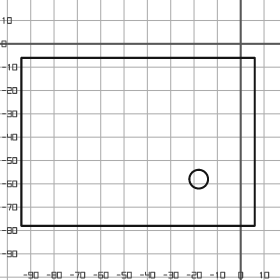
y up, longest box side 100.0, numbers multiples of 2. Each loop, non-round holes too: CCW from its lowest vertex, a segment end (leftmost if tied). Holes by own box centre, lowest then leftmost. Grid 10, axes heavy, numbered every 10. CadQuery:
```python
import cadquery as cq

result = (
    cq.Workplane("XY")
    .moveTo(-94.0, -78.0)
    .lineTo(6.0, -78.0)
    .lineTo(6.0, -6.0)
    .lineTo(-94.0, -6.0)
    .close()
    .moveTo(-18.0, -58.0)
    .circle(4.0)
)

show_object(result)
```